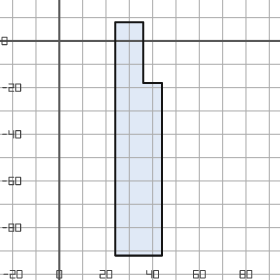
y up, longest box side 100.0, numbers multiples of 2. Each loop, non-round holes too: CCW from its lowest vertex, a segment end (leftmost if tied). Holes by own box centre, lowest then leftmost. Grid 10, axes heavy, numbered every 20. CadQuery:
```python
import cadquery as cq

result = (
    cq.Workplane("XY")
    .moveTo(24.0, -92.0)
    .lineTo(44.0, -92.0)
    .lineTo(44.0, -18.0)
    .lineTo(36.0, -18.0)
    .lineTo(36.0, 8.0)
    .lineTo(24.0, 8.0)
    .close()
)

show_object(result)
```